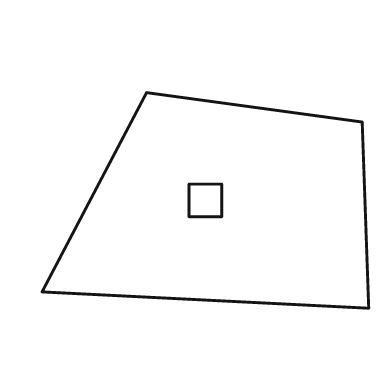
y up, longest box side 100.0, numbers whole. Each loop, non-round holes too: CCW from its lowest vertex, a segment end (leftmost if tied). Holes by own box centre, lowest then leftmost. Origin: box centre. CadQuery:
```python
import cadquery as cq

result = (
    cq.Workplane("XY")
    .moveTo(50.0, -33.0)
    .lineTo(48.0, 24.0)
    .lineTo(-18.0, 33.0)
    .lineTo(-50.0, -28.0)
    .close()
    .moveTo(-5.0, -5.0)
    .lineTo(5.0, -5.0)
    .lineTo(5.0, 5.0)
    .lineTo(-5.0, 5.0)
    .close()
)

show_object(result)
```